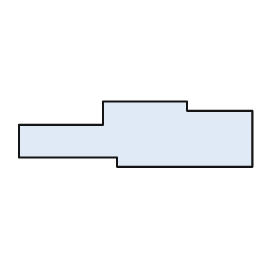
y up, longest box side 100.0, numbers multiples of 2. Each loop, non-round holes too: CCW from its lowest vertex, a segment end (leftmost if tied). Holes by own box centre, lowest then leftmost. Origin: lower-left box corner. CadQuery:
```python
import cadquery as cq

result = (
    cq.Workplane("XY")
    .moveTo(42.0, 0.0)
    .lineTo(100.0, 0.0)
    .lineTo(100.0, 24.0)
    .lineTo(72.0, 24.0)
    .lineTo(72.0, 28.0)
    .lineTo(36.0, 28.0)
    .lineTo(36.0, 18.0)
    .lineTo(0.0, 18.0)
    .lineTo(0.0, 4.0)
    .lineTo(42.0, 4.0)
    .close()
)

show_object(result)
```